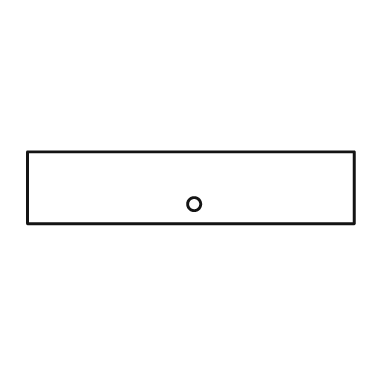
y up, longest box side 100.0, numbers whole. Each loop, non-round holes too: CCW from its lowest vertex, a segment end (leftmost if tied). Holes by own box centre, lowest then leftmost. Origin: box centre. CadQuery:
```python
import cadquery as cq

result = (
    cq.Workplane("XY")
    .moveTo(-50.0, -11.0)
    .lineTo(50.0, -11.0)
    .lineTo(50.0, 11.0)
    .lineTo(-50.0, 11.0)
    .close()
    .moveTo(1.0, -5.0)
    .circle(2.0)
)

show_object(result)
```